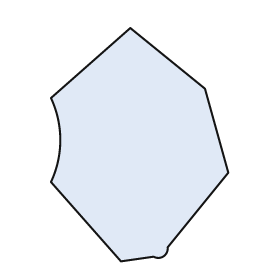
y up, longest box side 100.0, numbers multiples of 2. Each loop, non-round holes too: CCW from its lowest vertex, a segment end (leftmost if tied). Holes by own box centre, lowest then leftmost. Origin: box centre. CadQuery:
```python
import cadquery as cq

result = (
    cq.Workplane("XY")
    .moveTo(-8.0, -50.0)
    .lineTo(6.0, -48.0)
    .threePointArc((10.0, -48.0), (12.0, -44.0))
    .lineTo(38.0, -12.0)
    .lineTo(28.0, 24.0)
    .lineTo(-4.0, 50.0)
    .lineTo(-38.0, 20.0)
    .threePointArc((-34.0, 2.0), (-38.0, -16.0))
    .close()
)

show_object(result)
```